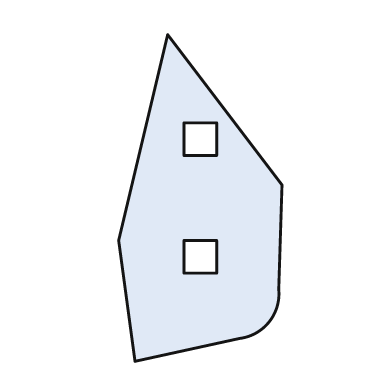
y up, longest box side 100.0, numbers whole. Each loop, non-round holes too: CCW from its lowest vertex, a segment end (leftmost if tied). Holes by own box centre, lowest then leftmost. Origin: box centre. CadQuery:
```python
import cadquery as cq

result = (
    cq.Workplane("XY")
    .moveTo(-20.0, -50.0)
    .lineTo(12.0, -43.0)
    .threePointArc((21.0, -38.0), (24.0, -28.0))
    .lineTo(25.0, 4.0)
    .lineTo(-10.0, 50.0)
    .lineTo(-25.0, -13.0)
    .close()
    .moveTo(-5.0, -23.0)
    .lineTo(5.0, -23.0)
    .lineTo(5.0, -13.0)
    .lineTo(-5.0, -13.0)
    .close()
    .moveTo(-5.0, 13.0)
    .lineTo(5.0, 13.0)
    .lineTo(5.0, 23.0)
    .lineTo(-5.0, 23.0)
    .close()
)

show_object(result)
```